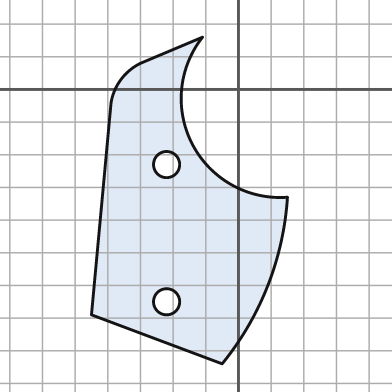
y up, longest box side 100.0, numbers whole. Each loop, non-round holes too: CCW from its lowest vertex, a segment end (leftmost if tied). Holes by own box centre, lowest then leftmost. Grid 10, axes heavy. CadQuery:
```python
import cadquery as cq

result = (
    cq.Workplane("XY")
    .moveTo(-5.0, -84.0)
    .threePointArc((9.0, -60.0), (15.0, -33.0))
    .threePointArc((-14.0, -17.0), (-11.0, 16.0))
    .lineTo(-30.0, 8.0)
    .threePointArc((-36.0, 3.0), (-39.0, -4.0))
    .lineTo(-45.0, -69.0)
    .close()
    .moveTo(-22.0, -65.0)
    .circle(4.0)
    .moveTo(-22.0, -23.0)
    .circle(4.0)
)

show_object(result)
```